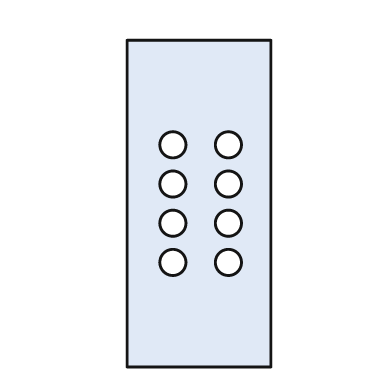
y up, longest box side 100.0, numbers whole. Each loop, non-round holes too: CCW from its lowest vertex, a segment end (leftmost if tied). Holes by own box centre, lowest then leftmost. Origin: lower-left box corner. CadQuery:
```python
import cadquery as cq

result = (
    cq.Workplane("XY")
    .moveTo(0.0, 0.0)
    .lineTo(44.0, 0.0)
    .lineTo(44.0, 100.0)
    .lineTo(0.0, 100.0)
    .close()
    .moveTo(14.0, 32.0)
    .circle(4.0)
    .moveTo(31.0, 32.0)
    .circle(4.0)
    .moveTo(14.0, 44.0)
    .circle(4.0)
    .moveTo(31.0, 44.0)
    .circle(4.0)
    .moveTo(14.0, 56.0)
    .circle(4.0)
    .moveTo(31.0, 56.0)
    .circle(4.0)
    .moveTo(14.0, 68.0)
    .circle(4.0)
    .moveTo(31.0, 68.0)
    .circle(4.0)
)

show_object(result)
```